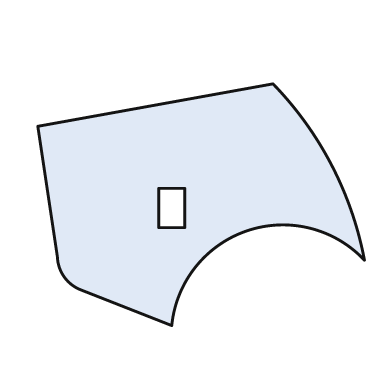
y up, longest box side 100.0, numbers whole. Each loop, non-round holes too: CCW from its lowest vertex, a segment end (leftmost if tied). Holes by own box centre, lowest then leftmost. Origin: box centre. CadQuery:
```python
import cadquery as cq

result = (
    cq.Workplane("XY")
    .moveTo(-9.0, -37.0)
    .threePointArc((14.0, -8.0), (50.0, -17.0))
    .threePointArc((40.0, 12.0), (22.0, 37.0))
    .lineTo(-50.0, 24.0)
    .lineTo(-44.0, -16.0)
    .threePointArc((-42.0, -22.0), (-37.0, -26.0))
    .close()
    .moveTo(-13.0, -7.0)
    .lineTo(-5.0, -7.0)
    .lineTo(-5.0, 5.0)
    .lineTo(-13.0, 5.0)
    .close()
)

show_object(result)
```